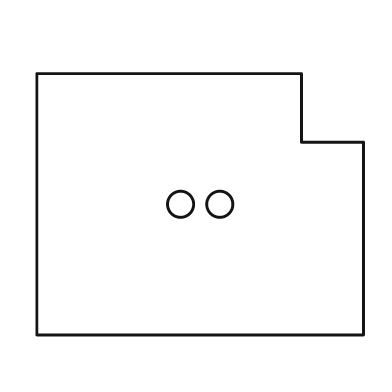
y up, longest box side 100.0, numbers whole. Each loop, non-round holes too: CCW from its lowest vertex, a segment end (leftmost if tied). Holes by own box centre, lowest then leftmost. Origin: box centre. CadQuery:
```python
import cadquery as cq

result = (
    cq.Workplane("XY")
    .moveTo(-50.0, -40.0)
    .lineTo(50.0, -40.0)
    .lineTo(50.0, 19.0)
    .lineTo(31.0, 19.0)
    .lineTo(31.0, 40.0)
    .lineTo(-50.0, 40.0)
    .close()
    .moveTo(-6.0, 0.0)
    .circle(4.0)
    .moveTo(6.0, 0.0)
    .circle(4.0)
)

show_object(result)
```